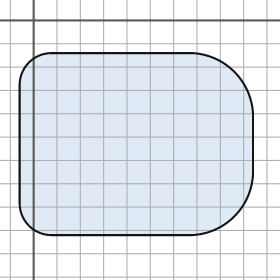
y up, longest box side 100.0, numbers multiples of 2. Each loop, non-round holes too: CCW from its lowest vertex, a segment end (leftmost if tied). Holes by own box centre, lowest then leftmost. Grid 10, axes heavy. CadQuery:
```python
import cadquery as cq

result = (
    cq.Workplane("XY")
    .moveTo(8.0, -92.0)
    .lineTo(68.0, -92.0)
    .threePointArc((86.0, -84.0), (94.0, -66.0))
    .lineTo(94.0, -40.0)
    .threePointArc((86.0, -22.0), (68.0, -14.0))
    .lineTo(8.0, -14.0)
    .threePointArc((-2.0, -18.0), (-6.0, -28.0))
    .lineTo(-6.0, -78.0)
    .threePointArc((-2.0, -88.0), (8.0, -92.0))
    .close()
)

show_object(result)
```